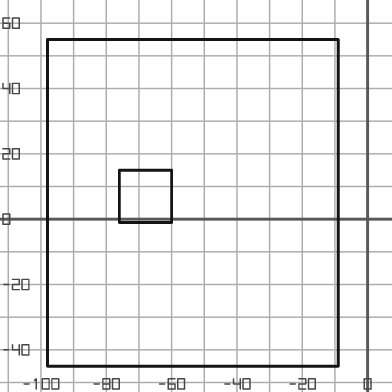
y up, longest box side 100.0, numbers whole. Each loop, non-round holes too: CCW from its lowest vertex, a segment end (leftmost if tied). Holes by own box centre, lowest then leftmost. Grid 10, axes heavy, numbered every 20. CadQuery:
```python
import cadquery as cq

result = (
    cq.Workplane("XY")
    .moveTo(-98.0, -45.0)
    .lineTo(-9.0, -45.0)
    .lineTo(-9.0, 55.0)
    .lineTo(-98.0, 55.0)
    .close()
    .moveTo(-76.0, -1.0)
    .lineTo(-60.0, -1.0)
    .lineTo(-60.0, 15.0)
    .lineTo(-76.0, 15.0)
    .close()
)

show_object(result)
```